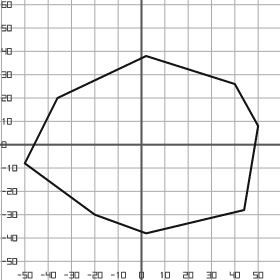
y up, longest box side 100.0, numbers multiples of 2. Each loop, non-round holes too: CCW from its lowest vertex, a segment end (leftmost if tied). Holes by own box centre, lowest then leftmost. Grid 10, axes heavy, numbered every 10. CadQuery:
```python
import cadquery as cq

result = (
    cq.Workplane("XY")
    .moveTo(2.0, -38.0)
    .lineTo(44.0, -28.0)
    .lineTo(50.0, 8.0)
    .lineTo(40.0, 26.0)
    .lineTo(2.0, 38.0)
    .lineTo(-36.0, 20.0)
    .lineTo(-50.0, -8.0)
    .lineTo(-20.0, -30.0)
    .close()
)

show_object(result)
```